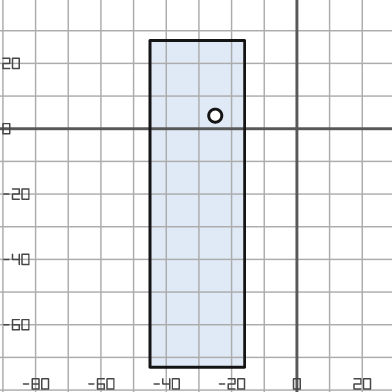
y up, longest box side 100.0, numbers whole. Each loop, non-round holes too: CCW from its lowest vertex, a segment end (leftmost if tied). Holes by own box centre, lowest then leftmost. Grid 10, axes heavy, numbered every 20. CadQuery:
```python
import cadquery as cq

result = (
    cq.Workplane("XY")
    .moveTo(-45.0, -73.0)
    .lineTo(-16.0, -73.0)
    .lineTo(-16.0, 27.0)
    .lineTo(-45.0, 27.0)
    .close()
    .moveTo(-25.0, 4.0)
    .circle(2.0)
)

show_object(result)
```